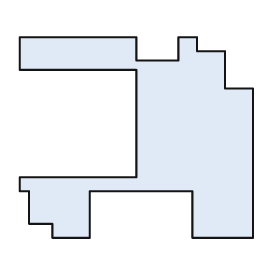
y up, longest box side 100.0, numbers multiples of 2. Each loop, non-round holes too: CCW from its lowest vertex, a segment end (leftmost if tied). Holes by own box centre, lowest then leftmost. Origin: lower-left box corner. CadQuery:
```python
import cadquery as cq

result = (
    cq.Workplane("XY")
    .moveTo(14.0, 0.0)
    .lineTo(30.0, 0.0)
    .lineTo(30.0, 20.0)
    .lineTo(74.0, 20.0)
    .lineTo(74.0, 0.0)
    .lineTo(100.0, 0.0)
    .lineTo(100.0, 64.0)
    .lineTo(88.0, 64.0)
    .lineTo(88.0, 80.0)
    .lineTo(76.0, 80.0)
    .lineTo(76.0, 86.0)
    .lineTo(68.0, 86.0)
    .lineTo(68.0, 76.0)
    .lineTo(50.0, 76.0)
    .lineTo(50.0, 86.0)
    .lineTo(0.0, 86.0)
    .lineTo(0.0, 72.0)
    .lineTo(50.0, 72.0)
    .lineTo(50.0, 26.0)
    .lineTo(0.0, 26.0)
    .lineTo(0.0, 20.0)
    .lineTo(4.0, 20.0)
    .lineTo(4.0, 6.0)
    .lineTo(14.0, 6.0)
    .close()
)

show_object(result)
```